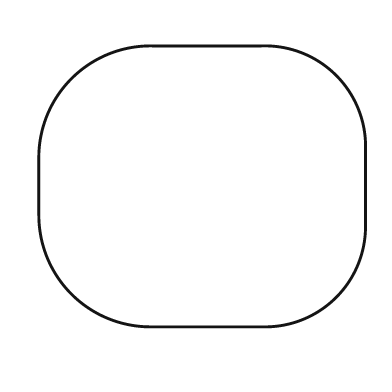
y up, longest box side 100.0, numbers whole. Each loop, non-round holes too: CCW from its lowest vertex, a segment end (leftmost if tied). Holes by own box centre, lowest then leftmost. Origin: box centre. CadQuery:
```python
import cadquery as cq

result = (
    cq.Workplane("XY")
    .moveTo(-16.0, -43.0)
    .lineTo(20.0, -43.0)
    .threePointArc((41.0, -34.0), (50.0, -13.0))
    .lineTo(50.0, 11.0)
    .threePointArc((41.0, 34.0), (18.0, 43.0))
    .lineTo(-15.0, 43.0)
    .threePointArc((-40.0, 33.0), (-50.0, 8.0))
    .lineTo(-50.0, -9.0)
    .threePointArc((-40.0, -33.0), (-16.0, -43.0))
    .close()
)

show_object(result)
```